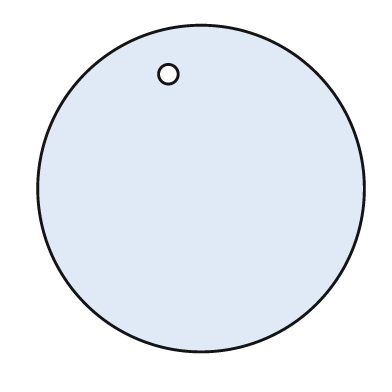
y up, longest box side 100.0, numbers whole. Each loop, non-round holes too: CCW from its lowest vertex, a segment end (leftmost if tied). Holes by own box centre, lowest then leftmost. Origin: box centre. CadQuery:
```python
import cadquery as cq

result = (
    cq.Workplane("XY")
    .moveTo(0.0, 0.0)
    .circle(50.0)
    .moveTo(-10.0, 35.0)
    .circle(3.0)
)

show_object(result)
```